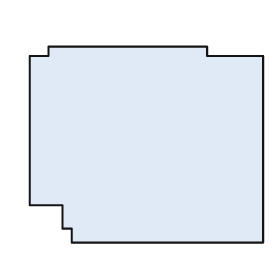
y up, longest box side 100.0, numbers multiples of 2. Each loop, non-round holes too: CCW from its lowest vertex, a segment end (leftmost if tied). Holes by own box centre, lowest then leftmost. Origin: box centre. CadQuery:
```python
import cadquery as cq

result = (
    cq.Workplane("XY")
    .moveTo(-32.0, -42.0)
    .lineTo(50.0, -42.0)
    .lineTo(50.0, 38.0)
    .lineTo(26.0, 38.0)
    .lineTo(26.0, 42.0)
    .lineTo(-42.0, 42.0)
    .lineTo(-42.0, 38.0)
    .lineTo(-50.0, 38.0)
    .lineTo(-50.0, -26.0)
    .lineTo(-36.0, -26.0)
    .lineTo(-36.0, -36.0)
    .lineTo(-32.0, -36.0)
    .close()
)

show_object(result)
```